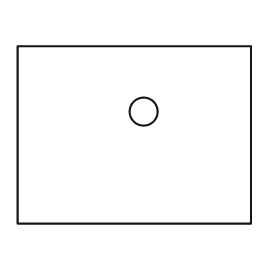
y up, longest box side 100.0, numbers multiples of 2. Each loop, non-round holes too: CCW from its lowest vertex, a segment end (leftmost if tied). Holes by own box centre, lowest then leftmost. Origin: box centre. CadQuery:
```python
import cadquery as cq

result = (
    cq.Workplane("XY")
    .moveTo(-50.0, -38.0)
    .lineTo(50.0, -38.0)
    .lineTo(50.0, 38.0)
    .lineTo(-50.0, 38.0)
    .close()
    .moveTo(4.0, 10.0)
    .circle(6.0)
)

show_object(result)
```